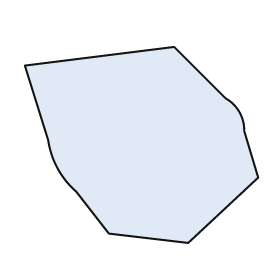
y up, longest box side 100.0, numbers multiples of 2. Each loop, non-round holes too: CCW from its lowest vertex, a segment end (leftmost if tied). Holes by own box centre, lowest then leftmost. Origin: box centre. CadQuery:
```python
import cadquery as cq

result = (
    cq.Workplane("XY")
    .moveTo(20.0, -42.0)
    .lineTo(50.0, -14.0)
    .lineTo(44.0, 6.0)
    .threePointArc((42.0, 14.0), (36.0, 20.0))
    .lineTo(14.0, 42.0)
    .lineTo(-50.0, 34.0)
    .lineTo(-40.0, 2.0)
    .threePointArc((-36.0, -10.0), (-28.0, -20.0))
    .lineTo(-14.0, -38.0)
    .close()
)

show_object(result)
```